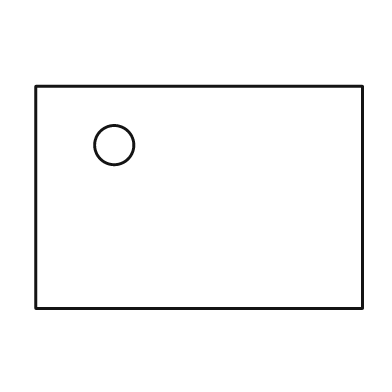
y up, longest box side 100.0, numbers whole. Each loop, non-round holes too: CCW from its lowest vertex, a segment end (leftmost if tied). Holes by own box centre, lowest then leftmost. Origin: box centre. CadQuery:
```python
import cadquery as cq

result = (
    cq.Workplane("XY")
    .moveTo(-50.0, -34.0)
    .lineTo(50.0, -34.0)
    .lineTo(50.0, 34.0)
    .lineTo(-50.0, 34.0)
    .close()
    .moveTo(-26.0, 16.0)
    .circle(6.0)
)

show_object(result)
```